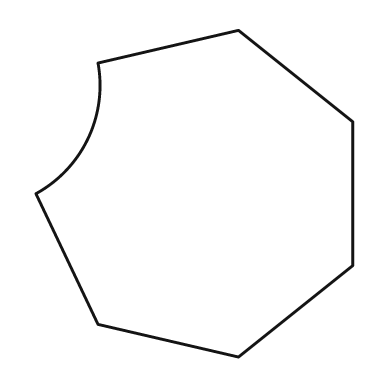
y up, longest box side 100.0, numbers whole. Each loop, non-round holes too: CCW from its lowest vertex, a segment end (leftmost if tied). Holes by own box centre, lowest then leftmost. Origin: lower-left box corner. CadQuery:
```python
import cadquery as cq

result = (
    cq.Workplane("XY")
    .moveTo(62.0, 0.0)
    .lineTo(97.0, 28.0)
    .lineTo(97.0, 72.0)
    .lineTo(62.0, 100.0)
    .lineTo(19.0, 90.0)
    .threePointArc((16.0, 67.0), (0.0, 50.0))
    .lineTo(19.0, 10.0)
    .close()
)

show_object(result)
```